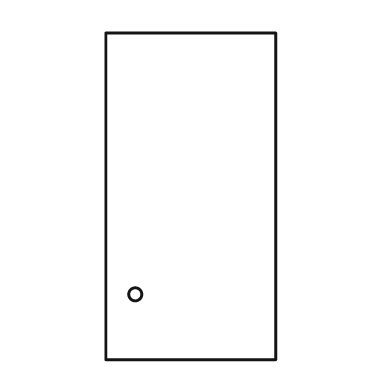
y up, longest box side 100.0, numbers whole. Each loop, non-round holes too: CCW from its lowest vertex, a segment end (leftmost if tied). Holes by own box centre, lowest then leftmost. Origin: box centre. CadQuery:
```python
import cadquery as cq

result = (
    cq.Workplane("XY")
    .moveTo(-26.0, -50.0)
    .lineTo(26.0, -50.0)
    .lineTo(26.0, 50.0)
    .lineTo(-26.0, 50.0)
    .close()
    .moveTo(-17.0, -30.0)
    .circle(2.0)
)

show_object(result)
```